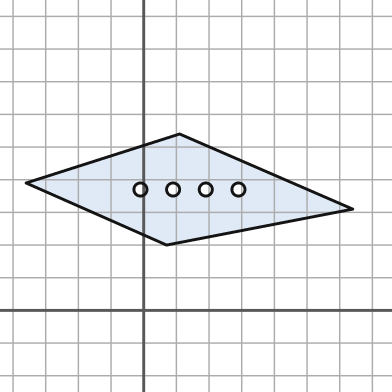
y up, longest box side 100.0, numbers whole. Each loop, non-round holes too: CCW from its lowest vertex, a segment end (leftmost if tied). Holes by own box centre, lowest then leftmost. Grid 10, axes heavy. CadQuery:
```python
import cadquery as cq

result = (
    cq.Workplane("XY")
    .moveTo(7.0, 20.0)
    .lineTo(64.0, 31.0)
    .lineTo(11.0, 54.0)
    .lineTo(-36.0, 39.0)
    .close()
    .moveTo(-1.0, 37.0)
    .circle(2.0)
    .moveTo(9.0, 37.0)
    .circle(2.0)
    .moveTo(19.0, 37.0)
    .circle(2.0)
    .moveTo(29.0, 37.0)
    .circle(2.0)
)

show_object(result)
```